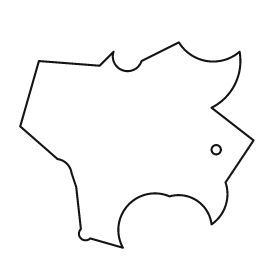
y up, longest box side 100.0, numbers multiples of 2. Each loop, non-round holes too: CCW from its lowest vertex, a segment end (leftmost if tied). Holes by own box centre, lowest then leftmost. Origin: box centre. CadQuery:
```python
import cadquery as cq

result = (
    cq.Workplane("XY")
    .moveTo(-6.0, -44.0)
    .threePointArc((-4.0, -26.0), (14.0, -22.0))
    .threePointArc((26.0, -24.0), (32.0, -34.0))
    .threePointArc((38.0, -26.0), (38.0, -16.0))
    .lineTo(50.0, 2.0)
    .lineTo(32.0, 16.0)
    .threePointArc((42.0, 26.0), (44.0, 40.0))
    .threePointArc((30.0, 36.0), (18.0, 44.0))
    .lineTo(2.0, 36.0)
    .threePointArc((-6.0, 32.0), (-10.0, 40.0))
    .lineTo(-16.0, 34.0)
    .lineTo(-42.0, 36.0)
    .lineTo(-50.0, 8.0)
    .lineTo(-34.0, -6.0)
    .threePointArc((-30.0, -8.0), (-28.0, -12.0))
    .lineTo(-26.0, -18.0)
    .lineTo(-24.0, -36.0)
    .threePointArc((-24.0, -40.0), (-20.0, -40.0))
    .close()
    .moveTo(34.0, -2.0)
    .circle(2.0)
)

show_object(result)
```